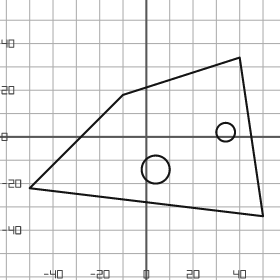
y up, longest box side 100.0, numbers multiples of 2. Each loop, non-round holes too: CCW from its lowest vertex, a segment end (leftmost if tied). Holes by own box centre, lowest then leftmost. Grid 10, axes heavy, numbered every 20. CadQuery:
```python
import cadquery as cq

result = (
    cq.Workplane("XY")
    .moveTo(50.0, -34.0)
    .lineTo(40.0, 34.0)
    .lineTo(-10.0, 18.0)
    .lineTo(-50.0, -22.0)
    .close()
    .moveTo(4.0, -14.0)
    .circle(6.0)
    .moveTo(34.0, 2.0)
    .circle(4.0)
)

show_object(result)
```